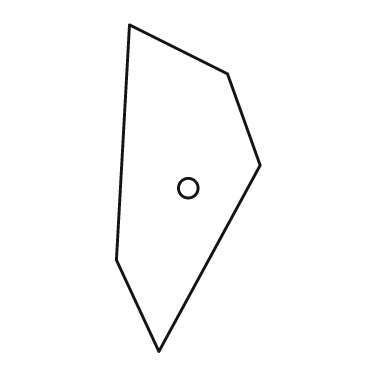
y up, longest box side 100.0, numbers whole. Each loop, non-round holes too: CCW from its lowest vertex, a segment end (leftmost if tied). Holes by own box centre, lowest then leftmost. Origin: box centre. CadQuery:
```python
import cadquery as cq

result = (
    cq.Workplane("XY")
    .moveTo(-9.0, -50.0)
    .lineTo(22.0, 7.0)
    .lineTo(12.0, 35.0)
    .lineTo(-18.0, 50.0)
    .lineTo(-22.0, -22.0)
    .close()
    .moveTo(0.0, 0.0)
    .circle(3.0)
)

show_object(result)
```